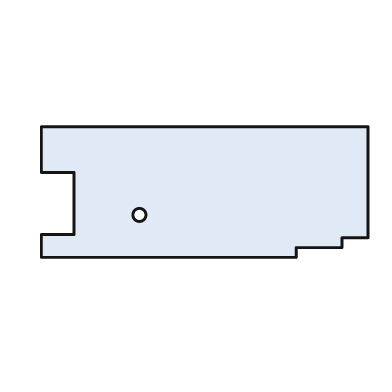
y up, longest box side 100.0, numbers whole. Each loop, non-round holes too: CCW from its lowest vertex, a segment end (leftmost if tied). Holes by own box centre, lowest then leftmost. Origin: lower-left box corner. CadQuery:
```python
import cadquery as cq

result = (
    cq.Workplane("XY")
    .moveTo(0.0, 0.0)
    .lineTo(78.0, 0.0)
    .lineTo(78.0, 3.0)
    .lineTo(92.0, 3.0)
    .lineTo(92.0, 6.0)
    .lineTo(100.0, 6.0)
    .lineTo(100.0, 40.0)
    .lineTo(0.0, 40.0)
    .lineTo(0.0, 26.0)
    .lineTo(10.0, 26.0)
    .lineTo(10.0, 7.0)
    .lineTo(0.0, 7.0)
    .close()
    .moveTo(30.0, 13.0)
    .circle(2.0)
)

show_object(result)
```